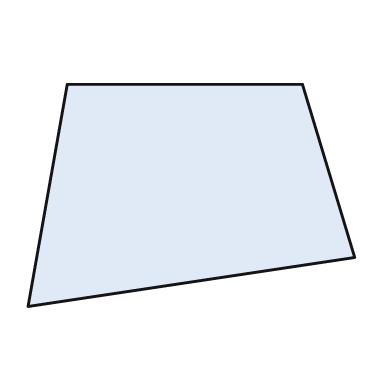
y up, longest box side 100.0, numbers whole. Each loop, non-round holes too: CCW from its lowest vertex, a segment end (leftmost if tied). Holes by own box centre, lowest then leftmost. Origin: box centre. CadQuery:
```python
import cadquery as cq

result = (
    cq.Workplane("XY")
    .moveTo(-50.0, -34.0)
    .lineTo(50.0, -19.0)
    .lineTo(34.0, 34.0)
    .lineTo(-38.0, 34.0)
    .close()
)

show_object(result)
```